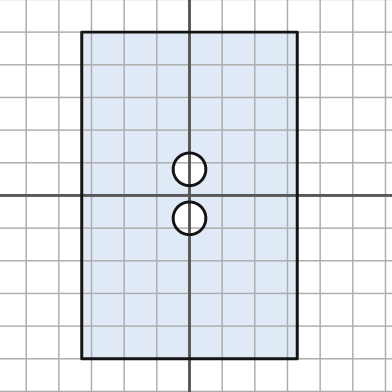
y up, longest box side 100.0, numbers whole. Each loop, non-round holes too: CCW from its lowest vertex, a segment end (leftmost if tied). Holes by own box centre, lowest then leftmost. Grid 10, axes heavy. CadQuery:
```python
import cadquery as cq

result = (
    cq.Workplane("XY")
    .moveTo(-33.0, -50.0)
    .lineTo(33.0, -50.0)
    .lineTo(33.0, 50.0)
    .lineTo(-33.0, 50.0)
    .close()
    .moveTo(0.0, -7.0)
    .circle(5.0)
    .moveTo(0.0, 8.0)
    .circle(5.0)
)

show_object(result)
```